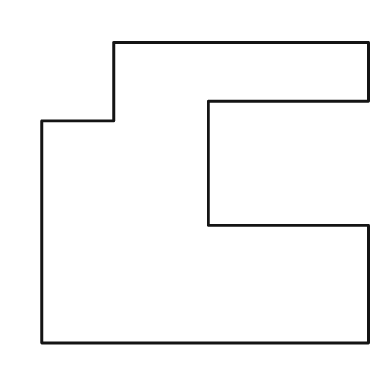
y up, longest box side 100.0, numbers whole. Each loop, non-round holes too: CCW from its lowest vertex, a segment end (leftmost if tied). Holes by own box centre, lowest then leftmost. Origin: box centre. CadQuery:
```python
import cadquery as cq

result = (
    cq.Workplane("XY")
    .moveTo(-50.0, -46.0)
    .lineTo(50.0, -46.0)
    .lineTo(50.0, -10.0)
    .lineTo(1.0, -10.0)
    .lineTo(1.0, 28.0)
    .lineTo(50.0, 28.0)
    .lineTo(50.0, 46.0)
    .lineTo(-28.0, 46.0)
    .lineTo(-28.0, 22.0)
    .lineTo(-50.0, 22.0)
    .close()
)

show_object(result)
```